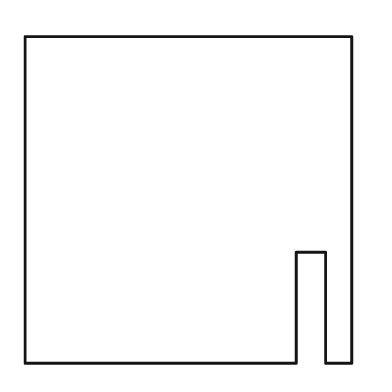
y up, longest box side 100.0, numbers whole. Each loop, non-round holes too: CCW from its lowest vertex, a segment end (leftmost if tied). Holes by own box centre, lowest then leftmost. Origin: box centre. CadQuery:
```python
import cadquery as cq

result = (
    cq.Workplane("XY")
    .moveTo(-50.0, -50.0)
    .lineTo(33.0, -50.0)
    .lineTo(33.0, -16.0)
    .lineTo(42.0, -16.0)
    .lineTo(42.0, -50.0)
    .lineTo(50.0, -50.0)
    .lineTo(50.0, 50.0)
    .lineTo(-50.0, 50.0)
    .close()
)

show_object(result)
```